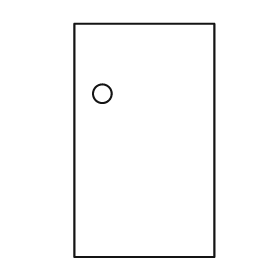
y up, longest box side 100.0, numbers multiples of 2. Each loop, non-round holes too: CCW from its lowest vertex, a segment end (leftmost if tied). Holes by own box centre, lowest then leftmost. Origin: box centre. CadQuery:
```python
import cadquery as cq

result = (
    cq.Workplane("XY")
    .moveTo(-30.0, -50.0)
    .lineTo(30.0, -50.0)
    .lineTo(30.0, 50.0)
    .lineTo(-30.0, 50.0)
    .close()
    .moveTo(-18.0, 20.0)
    .circle(4.0)
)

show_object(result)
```